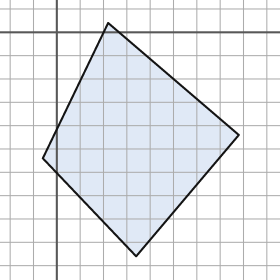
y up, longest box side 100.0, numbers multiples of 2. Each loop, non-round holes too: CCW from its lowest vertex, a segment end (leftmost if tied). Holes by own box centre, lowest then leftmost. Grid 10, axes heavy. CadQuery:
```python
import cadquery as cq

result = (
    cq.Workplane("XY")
    .moveTo(34.0, -96.0)
    .lineTo(78.0, -44.0)
    .lineTo(22.0, 4.0)
    .lineTo(-6.0, -54.0)
    .close()
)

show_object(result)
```